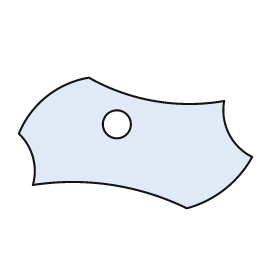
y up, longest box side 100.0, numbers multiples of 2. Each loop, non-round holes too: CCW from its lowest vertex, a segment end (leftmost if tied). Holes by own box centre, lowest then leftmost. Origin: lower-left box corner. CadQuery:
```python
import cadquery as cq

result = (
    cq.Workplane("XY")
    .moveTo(72.0, 0.0)
    .threePointArc((88.0, 8.0), (100.0, 22.0))
    .threePointArc((90.0, 32.0), (88.0, 46.0))
    .threePointArc((58.0, 46.0), (30.0, 56.0))
    .threePointArc((12.0, 48.0), (0.0, 32.0))
    .threePointArc((6.0, 22.0), (6.0, 10.0))
    .threePointArc((40.0, 10.0), (72.0, 0.0))
    .close()
    .moveTo(42.0, 36.0)
    .circle(6.0)
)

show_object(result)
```